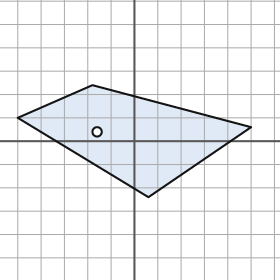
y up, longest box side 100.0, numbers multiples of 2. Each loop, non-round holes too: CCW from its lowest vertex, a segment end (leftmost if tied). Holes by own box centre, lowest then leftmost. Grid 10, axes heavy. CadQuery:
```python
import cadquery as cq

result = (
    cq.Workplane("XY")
    .moveTo(6.0, -24.0)
    .lineTo(50.0, 6.0)
    .lineTo(-18.0, 24.0)
    .lineTo(-50.0, 10.0)
    .close()
    .moveTo(-16.0, 4.0)
    .circle(2.0)
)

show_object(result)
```